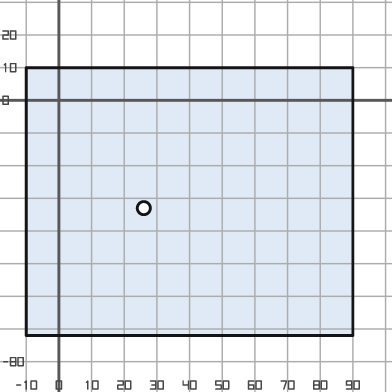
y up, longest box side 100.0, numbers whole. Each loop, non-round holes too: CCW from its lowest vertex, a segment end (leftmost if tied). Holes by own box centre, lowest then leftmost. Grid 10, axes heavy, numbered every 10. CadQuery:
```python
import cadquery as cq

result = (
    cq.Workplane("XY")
    .moveTo(-10.0, -72.0)
    .lineTo(90.0, -72.0)
    .lineTo(90.0, 10.0)
    .lineTo(-10.0, 10.0)
    .close()
    .moveTo(26.0, -33.0)
    .circle(2.0)
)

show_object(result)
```